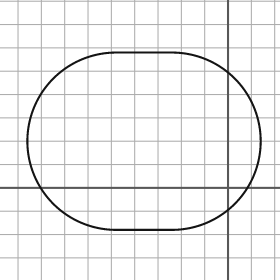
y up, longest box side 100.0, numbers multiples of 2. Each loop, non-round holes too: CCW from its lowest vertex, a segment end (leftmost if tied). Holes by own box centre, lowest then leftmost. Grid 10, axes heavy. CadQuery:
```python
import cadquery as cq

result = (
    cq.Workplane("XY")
    .moveTo(-48.0, -18.0)
    .lineTo(-24.0, -18.0)
    .threePointArc((14.0, 20.0), (-24.0, 58.0))
    .lineTo(-48.0, 58.0)
    .threePointArc((-86.0, 20.0), (-48.0, -18.0))
    .close()
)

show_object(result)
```